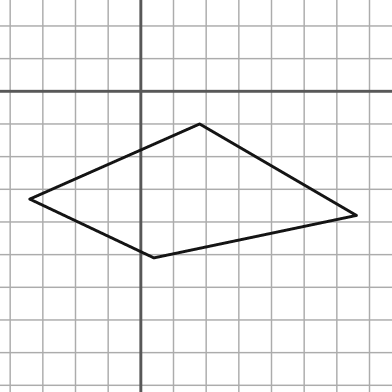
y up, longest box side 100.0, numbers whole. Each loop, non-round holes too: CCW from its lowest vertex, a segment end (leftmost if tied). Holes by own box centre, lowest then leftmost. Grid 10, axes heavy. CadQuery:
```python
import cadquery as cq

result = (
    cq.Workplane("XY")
    .moveTo(4.0, -51.0)
    .lineTo(66.0, -38.0)
    .lineTo(18.0, -10.0)
    .lineTo(-34.0, -33.0)
    .close()
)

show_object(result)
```